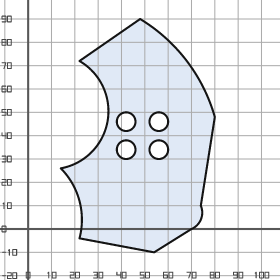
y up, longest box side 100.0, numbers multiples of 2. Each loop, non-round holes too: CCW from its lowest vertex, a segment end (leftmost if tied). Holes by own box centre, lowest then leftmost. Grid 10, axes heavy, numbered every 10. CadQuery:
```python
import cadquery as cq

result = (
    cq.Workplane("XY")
    .moveTo(54.0, -10.0)
    .lineTo(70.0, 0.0)
    .threePointArc((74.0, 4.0), (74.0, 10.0))
    .lineTo(80.0, 48.0)
    .threePointArc((68.0, 72.0), (48.0, 90.0))
    .lineTo(22.0, 72.0)
    .threePointArc((34.0, 46.0), (14.0, 26.0))
    .threePointArc((22.0, 12.0), (22.0, -4.0))
    .close()
    .moveTo(42.0, 34.0)
    .circle(4.0)
    .moveTo(56.0, 34.0)
    .circle(4.0)
    .moveTo(42.0, 46.0)
    .circle(4.0)
    .moveTo(56.0, 46.0)
    .circle(4.0)
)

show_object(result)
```